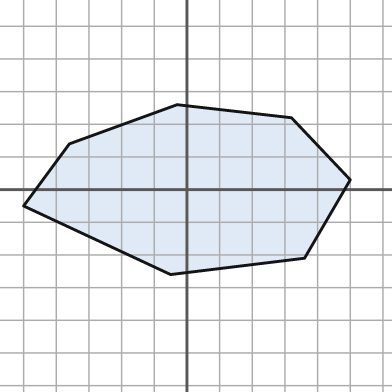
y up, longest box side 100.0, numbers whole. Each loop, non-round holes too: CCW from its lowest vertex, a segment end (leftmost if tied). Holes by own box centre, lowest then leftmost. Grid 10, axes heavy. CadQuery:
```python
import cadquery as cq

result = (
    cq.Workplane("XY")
    .moveTo(-5.0, -26.0)
    .lineTo(36.0, -21.0)
    .lineTo(50.0, 3.0)
    .lineTo(32.0, 22.0)
    .lineTo(-3.0, 26.0)
    .lineTo(-36.0, 14.0)
    .lineTo(-50.0, -5.0)
    .close()
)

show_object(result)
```